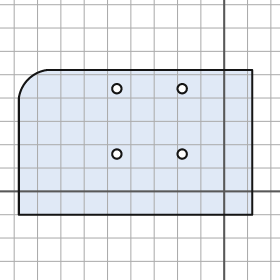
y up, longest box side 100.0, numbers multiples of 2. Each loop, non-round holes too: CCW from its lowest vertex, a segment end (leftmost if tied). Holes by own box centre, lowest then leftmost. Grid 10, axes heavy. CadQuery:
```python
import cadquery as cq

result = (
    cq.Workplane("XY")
    .moveTo(-88.0, -10.0)
    .lineTo(12.0, -10.0)
    .lineTo(12.0, 52.0)
    .lineTo(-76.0, 52.0)
    .threePointArc((-84.0, 48.0), (-88.0, 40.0))
    .close()
    .moveTo(-46.0, 16.0)
    .circle(2.0)
    .moveTo(-18.0, 16.0)
    .circle(2.0)
    .moveTo(-46.0, 44.0)
    .circle(2.0)
    .moveTo(-18.0, 44.0)
    .circle(2.0)
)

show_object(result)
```